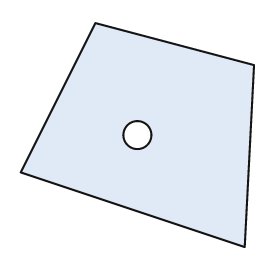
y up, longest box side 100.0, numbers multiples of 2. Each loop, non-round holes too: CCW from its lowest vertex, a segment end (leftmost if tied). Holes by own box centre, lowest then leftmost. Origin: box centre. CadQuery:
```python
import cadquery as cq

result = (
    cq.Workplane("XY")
    .moveTo(46.0, -48.0)
    .lineTo(50.0, 30.0)
    .lineTo(-18.0, 48.0)
    .lineTo(-50.0, -16.0)
    .close()
    .moveTo(0.0, 0.0)
    .circle(6.0)
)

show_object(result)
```